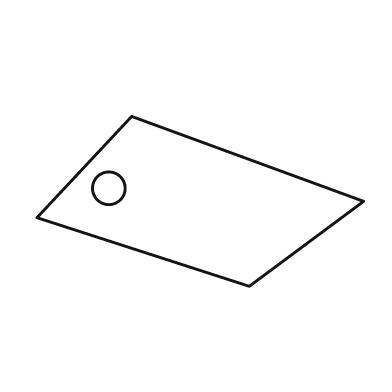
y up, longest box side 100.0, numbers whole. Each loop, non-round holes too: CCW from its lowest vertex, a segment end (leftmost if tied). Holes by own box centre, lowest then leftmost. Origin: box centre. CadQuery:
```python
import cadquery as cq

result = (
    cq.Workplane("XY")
    .moveTo(15.0, -26.0)
    .lineTo(50.0, 0.0)
    .lineTo(-21.0, 26.0)
    .lineTo(-50.0, -5.0)
    .close()
    .moveTo(-28.0, 4.0)
    .circle(5.0)
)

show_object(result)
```